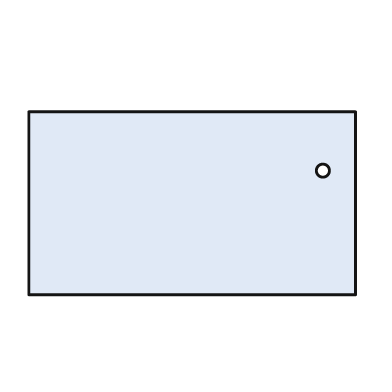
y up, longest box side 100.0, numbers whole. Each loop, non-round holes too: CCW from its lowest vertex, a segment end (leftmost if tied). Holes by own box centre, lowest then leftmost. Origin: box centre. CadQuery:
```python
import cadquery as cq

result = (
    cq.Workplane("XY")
    .moveTo(-50.0, -28.0)
    .lineTo(50.0, -28.0)
    .lineTo(50.0, 28.0)
    .lineTo(-50.0, 28.0)
    .close()
    .moveTo(40.0, 10.0)
    .circle(2.0)
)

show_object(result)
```